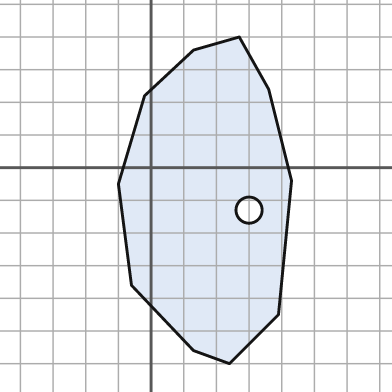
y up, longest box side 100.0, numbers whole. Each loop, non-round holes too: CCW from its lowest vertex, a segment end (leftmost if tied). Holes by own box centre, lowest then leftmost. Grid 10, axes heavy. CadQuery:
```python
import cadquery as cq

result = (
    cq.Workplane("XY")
    .moveTo(24.0, -60.0)
    .lineTo(39.0, -45.0)
    .lineTo(43.0, -4.0)
    .lineTo(36.0, 24.0)
    .lineTo(27.0, 40.0)
    .lineTo(13.0, 36.0)
    .lineTo(-2.0, 22.0)
    .lineTo(-10.0, -5.0)
    .lineTo(-6.0, -36.0)
    .lineTo(13.0, -56.0)
    .close()
    .moveTo(30.0, -13.0)
    .circle(4.0)
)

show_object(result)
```